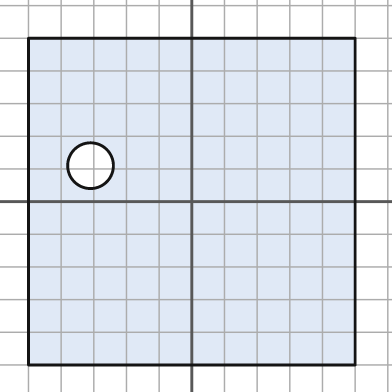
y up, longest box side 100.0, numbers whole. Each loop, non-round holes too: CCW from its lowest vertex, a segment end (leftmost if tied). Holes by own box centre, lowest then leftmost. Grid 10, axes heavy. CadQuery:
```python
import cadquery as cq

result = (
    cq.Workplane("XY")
    .moveTo(-50.0, -50.0)
    .lineTo(50.0, -50.0)
    .lineTo(50.0, 50.0)
    .lineTo(-50.0, 50.0)
    .close()
    .moveTo(-31.0, 11.0)
    .circle(7.0)
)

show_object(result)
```